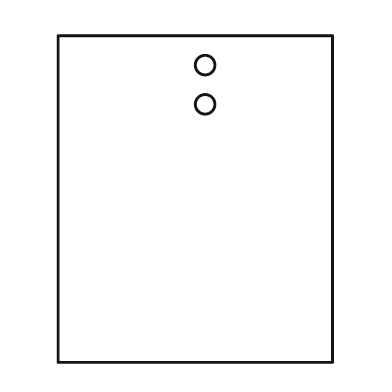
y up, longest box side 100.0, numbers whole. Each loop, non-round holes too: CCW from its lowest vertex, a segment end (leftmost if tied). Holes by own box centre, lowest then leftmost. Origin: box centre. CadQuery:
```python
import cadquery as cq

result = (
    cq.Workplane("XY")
    .moveTo(-42.0, -50.0)
    .lineTo(42.0, -50.0)
    .lineTo(42.0, 50.0)
    .lineTo(-42.0, 50.0)
    .close()
    .moveTo(3.0, 29.0)
    .circle(3.0)
    .moveTo(3.0, 41.0)
    .circle(3.0)
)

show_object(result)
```